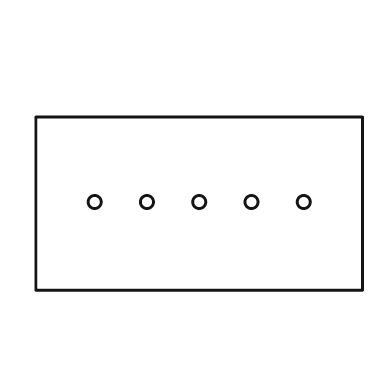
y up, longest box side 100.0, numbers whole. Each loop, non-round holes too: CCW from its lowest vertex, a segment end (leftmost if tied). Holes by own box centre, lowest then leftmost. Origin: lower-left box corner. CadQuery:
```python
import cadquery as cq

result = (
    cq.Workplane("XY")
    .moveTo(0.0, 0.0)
    .lineTo(100.0, 0.0)
    .lineTo(100.0, 53.0)
    .lineTo(0.0, 53.0)
    .close()
    .moveTo(18.0, 27.0)
    .circle(2.0)
    .moveTo(34.0, 27.0)
    .circle(2.0)
    .moveTo(50.0, 27.0)
    .circle(2.0)
    .moveTo(66.0, 27.0)
    .circle(2.0)
    .moveTo(82.0, 27.0)
    .circle(2.0)
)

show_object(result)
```